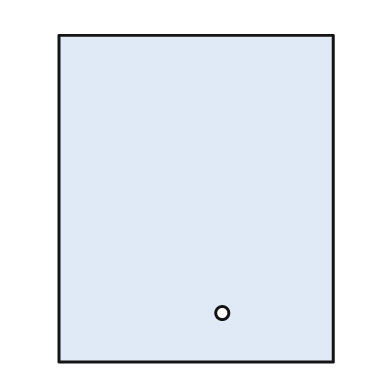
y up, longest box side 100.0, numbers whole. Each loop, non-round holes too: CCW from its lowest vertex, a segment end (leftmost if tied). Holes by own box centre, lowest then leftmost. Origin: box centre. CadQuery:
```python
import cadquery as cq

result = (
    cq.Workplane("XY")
    .moveTo(-42.0, -50.0)
    .lineTo(42.0, -50.0)
    .lineTo(42.0, 50.0)
    .lineTo(-42.0, 50.0)
    .close()
    .moveTo(8.0, -35.0)
    .circle(2.0)
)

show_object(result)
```